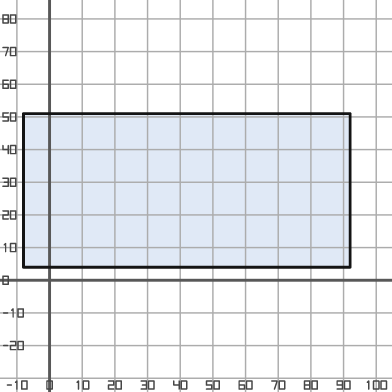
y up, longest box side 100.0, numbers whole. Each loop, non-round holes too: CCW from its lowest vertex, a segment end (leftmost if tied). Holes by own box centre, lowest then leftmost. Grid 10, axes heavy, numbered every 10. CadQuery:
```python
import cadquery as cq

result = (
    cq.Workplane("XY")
    .moveTo(-8.0, 4.0)
    .lineTo(92.0, 4.0)
    .lineTo(92.0, 51.0)
    .lineTo(-8.0, 51.0)
    .close()
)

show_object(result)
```